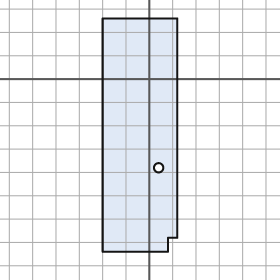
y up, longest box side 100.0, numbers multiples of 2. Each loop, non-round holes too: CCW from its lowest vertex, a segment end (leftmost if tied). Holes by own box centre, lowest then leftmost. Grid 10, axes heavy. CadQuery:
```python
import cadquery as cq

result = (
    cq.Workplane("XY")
    .moveTo(-20.0, -74.0)
    .lineTo(8.0, -74.0)
    .lineTo(8.0, -68.0)
    .lineTo(12.0, -68.0)
    .lineTo(12.0, 26.0)
    .lineTo(-20.0, 26.0)
    .close()
    .moveTo(4.0, -38.0)
    .circle(2.0)
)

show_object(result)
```